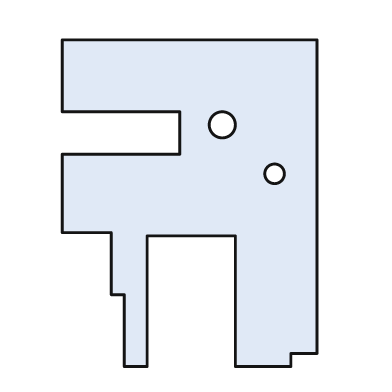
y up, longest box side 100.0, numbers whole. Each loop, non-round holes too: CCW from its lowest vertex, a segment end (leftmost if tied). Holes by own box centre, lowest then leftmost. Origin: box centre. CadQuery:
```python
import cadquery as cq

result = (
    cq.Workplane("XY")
    .moveTo(-20.0, -50.0)
    .lineTo(-13.0, -50.0)
    .lineTo(-13.0, -10.0)
    .lineTo(14.0, -10.0)
    .lineTo(14.0, -50.0)
    .lineTo(31.0, -50.0)
    .lineTo(31.0, -46.0)
    .lineTo(39.0, -46.0)
    .lineTo(39.0, 50.0)
    .lineTo(-39.0, 50.0)
    .lineTo(-39.0, 28.0)
    .lineTo(-3.0, 28.0)
    .lineTo(-3.0, 15.0)
    .lineTo(-39.0, 15.0)
    .lineTo(-39.0, -9.0)
    .lineTo(-24.0, -9.0)
    .lineTo(-24.0, -28.0)
    .lineTo(-20.0, -28.0)
    .close()
    .moveTo(26.0, 9.0)
    .circle(3.0)
    .moveTo(10.0, 24.0)
    .circle(4.0)
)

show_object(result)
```